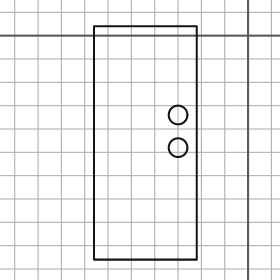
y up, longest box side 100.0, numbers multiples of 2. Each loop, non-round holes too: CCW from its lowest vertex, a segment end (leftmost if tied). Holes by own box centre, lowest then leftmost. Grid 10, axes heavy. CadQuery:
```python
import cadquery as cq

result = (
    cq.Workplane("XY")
    .moveTo(-66.0, -96.0)
    .lineTo(-22.0, -96.0)
    .lineTo(-22.0, 4.0)
    .lineTo(-66.0, 4.0)
    .close()
    .moveTo(-30.0, -48.0)
    .circle(4.0)
    .moveTo(-30.0, -34.0)
    .circle(4.0)
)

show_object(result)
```